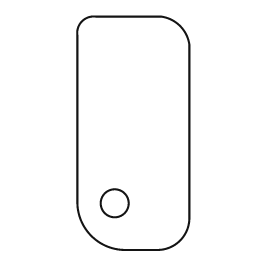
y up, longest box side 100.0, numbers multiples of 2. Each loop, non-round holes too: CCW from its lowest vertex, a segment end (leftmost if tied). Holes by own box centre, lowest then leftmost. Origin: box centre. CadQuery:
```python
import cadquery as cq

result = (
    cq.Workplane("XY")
    .moveTo(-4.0, -50.0)
    .lineTo(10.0, -50.0)
    .threePointArc((20.0, -46.0), (24.0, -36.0))
    .lineTo(24.0, 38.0)
    .threePointArc((20.0, 46.0), (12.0, 50.0))
    .lineTo(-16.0, 50.0)
    .threePointArc((-22.0, 48.0), (-24.0, 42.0))
    .lineTo(-24.0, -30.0)
    .threePointArc((-18.0, -44.0), (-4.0, -50.0))
    .close()
    .moveTo(-8.0, -30.0)
    .circle(6.0)
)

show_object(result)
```